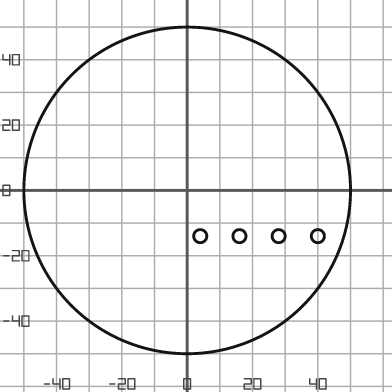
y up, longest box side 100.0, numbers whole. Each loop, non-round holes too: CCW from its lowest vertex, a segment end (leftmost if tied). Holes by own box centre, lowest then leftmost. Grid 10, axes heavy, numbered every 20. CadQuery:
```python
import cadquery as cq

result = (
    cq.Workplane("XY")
    .moveTo(0.0, 0.0)
    .circle(50.0)
    .moveTo(4.0, -14.0)
    .circle(2.0)
    .moveTo(16.0, -14.0)
    .circle(2.0)
    .moveTo(28.0, -14.0)
    .circle(2.0)
    .moveTo(40.0, -14.0)
    .circle(2.0)
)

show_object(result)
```